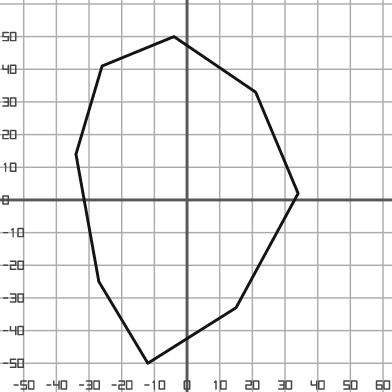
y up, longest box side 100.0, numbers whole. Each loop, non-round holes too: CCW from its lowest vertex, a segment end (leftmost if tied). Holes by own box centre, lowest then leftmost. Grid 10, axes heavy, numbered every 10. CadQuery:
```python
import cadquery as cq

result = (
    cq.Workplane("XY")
    .moveTo(-12.0, -50.0)
    .lineTo(15.0, -33.0)
    .lineTo(34.0, 2.0)
    .lineTo(21.0, 33.0)
    .lineTo(-4.0, 50.0)
    .lineTo(-26.0, 41.0)
    .lineTo(-34.0, 14.0)
    .lineTo(-27.0, -25.0)
    .close()
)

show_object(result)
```